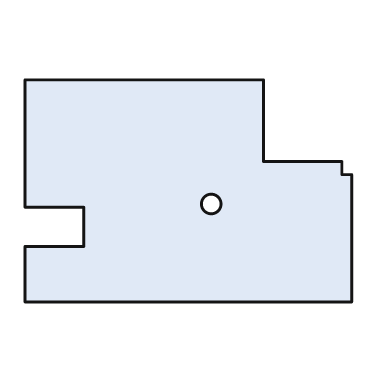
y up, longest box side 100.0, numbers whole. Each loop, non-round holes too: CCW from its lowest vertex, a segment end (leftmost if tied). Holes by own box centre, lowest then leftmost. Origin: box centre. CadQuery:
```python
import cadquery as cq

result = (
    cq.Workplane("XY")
    .moveTo(-50.0, -34.0)
    .lineTo(50.0, -34.0)
    .lineTo(50.0, 5.0)
    .lineTo(47.0, 5.0)
    .lineTo(47.0, 9.0)
    .lineTo(23.0, 9.0)
    .lineTo(23.0, 34.0)
    .lineTo(-50.0, 34.0)
    .lineTo(-50.0, -5.0)
    .lineTo(-32.0, -5.0)
    .lineTo(-32.0, -17.0)
    .lineTo(-50.0, -17.0)
    .close()
    .moveTo(7.0, -4.0)
    .circle(3.0)
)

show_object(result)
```